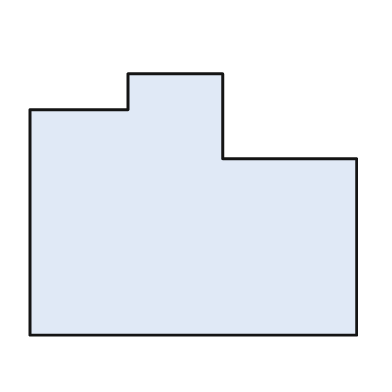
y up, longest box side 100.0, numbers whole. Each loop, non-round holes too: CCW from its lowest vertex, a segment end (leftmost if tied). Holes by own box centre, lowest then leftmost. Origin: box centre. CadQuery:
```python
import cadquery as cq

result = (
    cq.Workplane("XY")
    .moveTo(-50.0, -40.0)
    .lineTo(50.0, -40.0)
    .lineTo(50.0, 14.0)
    .lineTo(9.0, 14.0)
    .lineTo(9.0, 40.0)
    .lineTo(-20.0, 40.0)
    .lineTo(-20.0, 29.0)
    .lineTo(-50.0, 29.0)
    .close()
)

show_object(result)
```